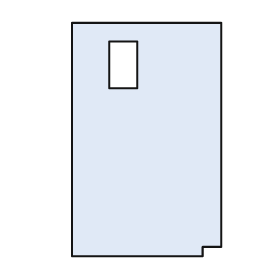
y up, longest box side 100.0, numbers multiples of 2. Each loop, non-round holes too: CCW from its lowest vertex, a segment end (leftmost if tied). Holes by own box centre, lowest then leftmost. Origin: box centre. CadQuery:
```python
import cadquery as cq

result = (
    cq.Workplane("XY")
    .moveTo(-32.0, -50.0)
    .lineTo(24.0, -50.0)
    .lineTo(24.0, -46.0)
    .lineTo(32.0, -46.0)
    .lineTo(32.0, 50.0)
    .lineTo(-32.0, 50.0)
    .close()
    .moveTo(-16.0, 22.0)
    .lineTo(-4.0, 22.0)
    .lineTo(-4.0, 42.0)
    .lineTo(-16.0, 42.0)
    .close()
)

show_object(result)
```